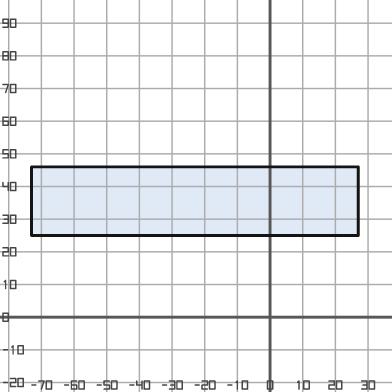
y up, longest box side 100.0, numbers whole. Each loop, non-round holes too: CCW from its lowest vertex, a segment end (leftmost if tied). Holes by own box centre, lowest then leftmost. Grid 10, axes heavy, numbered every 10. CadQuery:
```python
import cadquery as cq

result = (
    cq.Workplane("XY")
    .moveTo(-73.0, 25.0)
    .lineTo(27.0, 25.0)
    .lineTo(27.0, 46.0)
    .lineTo(-73.0, 46.0)
    .close()
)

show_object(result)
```